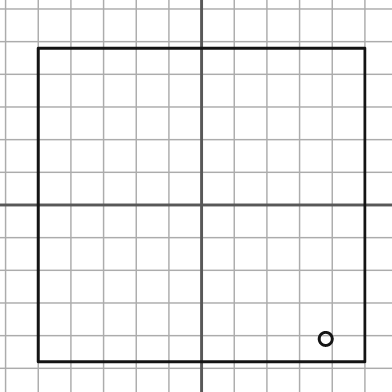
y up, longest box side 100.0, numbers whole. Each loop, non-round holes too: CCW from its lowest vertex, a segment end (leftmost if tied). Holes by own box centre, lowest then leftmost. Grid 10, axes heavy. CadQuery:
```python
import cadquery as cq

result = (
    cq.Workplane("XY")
    .moveTo(-50.0, -48.0)
    .lineTo(50.0, -48.0)
    .lineTo(50.0, 48.0)
    .lineTo(-50.0, 48.0)
    .close()
    .moveTo(38.0, -41.0)
    .circle(2.0)
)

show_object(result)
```